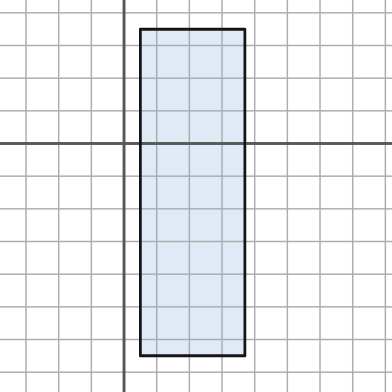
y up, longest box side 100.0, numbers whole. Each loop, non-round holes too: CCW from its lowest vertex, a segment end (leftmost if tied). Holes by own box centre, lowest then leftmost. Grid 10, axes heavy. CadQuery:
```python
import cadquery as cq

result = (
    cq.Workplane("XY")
    .moveTo(5.0, -65.0)
    .lineTo(37.0, -65.0)
    .lineTo(37.0, 35.0)
    .lineTo(5.0, 35.0)
    .close()
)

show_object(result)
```